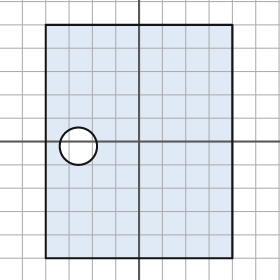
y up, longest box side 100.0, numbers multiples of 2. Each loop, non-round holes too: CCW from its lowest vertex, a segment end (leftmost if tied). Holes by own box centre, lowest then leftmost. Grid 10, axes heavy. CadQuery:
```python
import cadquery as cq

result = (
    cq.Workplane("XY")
    .moveTo(-40.0, -50.0)
    .lineTo(40.0, -50.0)
    .lineTo(40.0, 50.0)
    .lineTo(-40.0, 50.0)
    .close()
    .moveTo(-26.0, -2.0)
    .circle(8.0)
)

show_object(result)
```